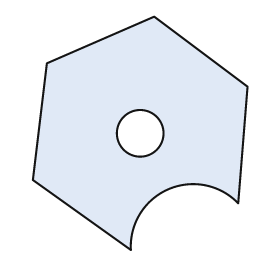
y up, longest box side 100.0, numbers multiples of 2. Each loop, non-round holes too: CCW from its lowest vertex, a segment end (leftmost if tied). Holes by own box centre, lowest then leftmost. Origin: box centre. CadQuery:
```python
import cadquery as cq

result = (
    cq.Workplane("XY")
    .moveTo(-4.0, -50.0)
    .threePointArc((12.0, -24.0), (42.0, -30.0))
    .lineTo(46.0, 20.0)
    .lineTo(6.0, 50.0)
    .lineTo(-40.0, 30.0)
    .lineTo(-46.0, -20.0)
    .close()
    .moveTo(0.0, 0.0)
    .circle(10.0)
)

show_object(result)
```